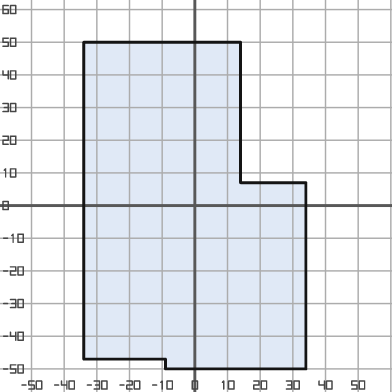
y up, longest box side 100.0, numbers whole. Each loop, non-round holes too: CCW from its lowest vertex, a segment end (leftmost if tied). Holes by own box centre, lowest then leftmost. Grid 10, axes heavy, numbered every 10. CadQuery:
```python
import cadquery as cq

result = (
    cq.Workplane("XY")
    .moveTo(-9.0, -50.0)
    .lineTo(34.0, -50.0)
    .lineTo(34.0, 7.0)
    .lineTo(14.0, 7.0)
    .lineTo(14.0, 50.0)
    .lineTo(-34.0, 50.0)
    .lineTo(-34.0, -47.0)
    .lineTo(-9.0, -47.0)
    .close()
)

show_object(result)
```